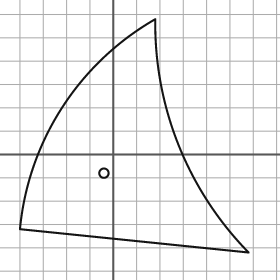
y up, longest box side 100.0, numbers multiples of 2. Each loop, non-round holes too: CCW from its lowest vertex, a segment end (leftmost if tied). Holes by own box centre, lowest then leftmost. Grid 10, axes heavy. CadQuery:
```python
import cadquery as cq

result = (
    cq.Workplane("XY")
    .moveTo(58.0, -42.0)
    .threePointArc((28.0, 4.0), (18.0, 58.0))
    .threePointArc((-22.0, 20.0), (-40.0, -32.0))
    .close()
    .moveTo(-4.0, -8.0)
    .circle(2.0)
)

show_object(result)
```